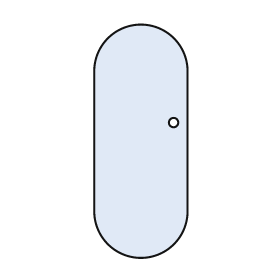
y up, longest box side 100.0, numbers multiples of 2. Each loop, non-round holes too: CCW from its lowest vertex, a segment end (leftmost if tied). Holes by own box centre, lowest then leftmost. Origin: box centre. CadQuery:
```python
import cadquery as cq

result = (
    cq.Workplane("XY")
    .moveTo(-20.0, -30.0)
    .threePointArc((0.0, -50.0), (20.0, -30.0))
    .lineTo(20.0, 30.0)
    .threePointArc((0.0, 50.0), (-20.0, 30.0))
    .close()
    .moveTo(14.0, 8.0)
    .circle(2.0)
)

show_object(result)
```